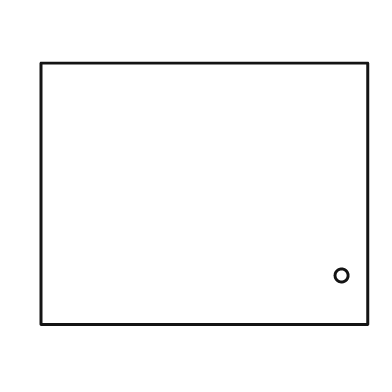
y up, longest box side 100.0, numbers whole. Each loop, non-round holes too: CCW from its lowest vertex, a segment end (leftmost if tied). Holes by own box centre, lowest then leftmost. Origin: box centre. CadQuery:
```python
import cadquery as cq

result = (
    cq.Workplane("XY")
    .moveTo(-50.0, -40.0)
    .lineTo(50.0, -40.0)
    .lineTo(50.0, 40.0)
    .lineTo(-50.0, 40.0)
    .close()
    .moveTo(42.0, -25.0)
    .circle(2.0)
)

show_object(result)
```